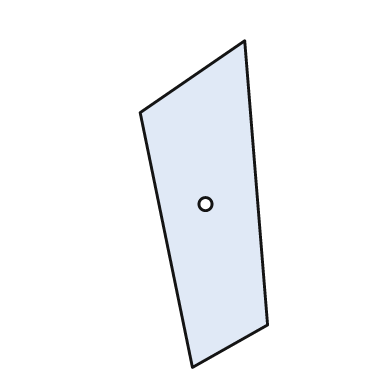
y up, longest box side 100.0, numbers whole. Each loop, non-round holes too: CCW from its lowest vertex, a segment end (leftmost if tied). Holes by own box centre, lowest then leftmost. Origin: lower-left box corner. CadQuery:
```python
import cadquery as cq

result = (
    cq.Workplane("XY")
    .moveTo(16.0, 0.0)
    .lineTo(39.0, 13.0)
    .lineTo(32.0, 100.0)
    .lineTo(0.0, 78.0)
    .close()
    .moveTo(20.0, 50.0)
    .circle(2.0)
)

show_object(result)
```